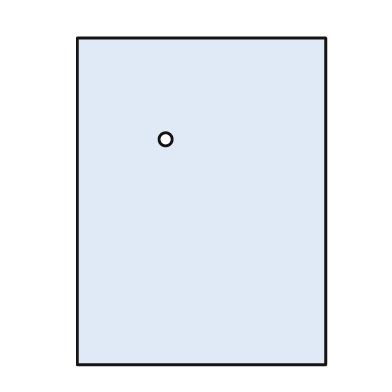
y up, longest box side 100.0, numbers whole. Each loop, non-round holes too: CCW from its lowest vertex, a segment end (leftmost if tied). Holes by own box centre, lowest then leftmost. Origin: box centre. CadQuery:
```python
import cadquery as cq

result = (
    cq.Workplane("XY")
    .moveTo(-38.0, -50.0)
    .lineTo(38.0, -50.0)
    .lineTo(38.0, 50.0)
    .lineTo(-38.0, 50.0)
    .close()
    .moveTo(-11.0, 19.0)
    .circle(2.0)
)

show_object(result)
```